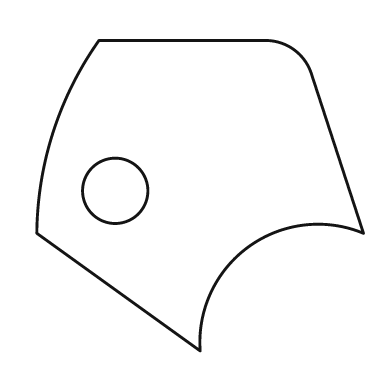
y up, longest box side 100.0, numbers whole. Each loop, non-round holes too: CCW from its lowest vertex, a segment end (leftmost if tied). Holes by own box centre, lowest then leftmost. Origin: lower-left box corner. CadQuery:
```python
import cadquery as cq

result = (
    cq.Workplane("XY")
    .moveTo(50.0, 0.0)
    .threePointArc((65.0, 32.0), (100.0, 36.0))
    .lineTo(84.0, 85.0)
    .threePointArc((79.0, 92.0), (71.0, 95.0))
    .lineTo(19.0, 95.0)
    .threePointArc((5.0, 67.0), (0.0, 36.0))
    .close()
    .moveTo(24.0, 49.0)
    .circle(10.0)
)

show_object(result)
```